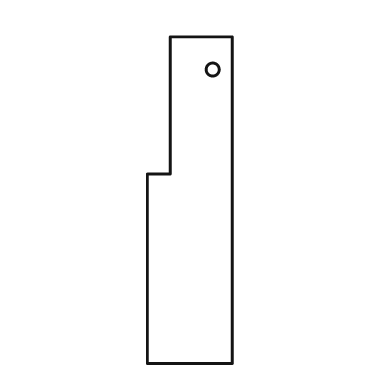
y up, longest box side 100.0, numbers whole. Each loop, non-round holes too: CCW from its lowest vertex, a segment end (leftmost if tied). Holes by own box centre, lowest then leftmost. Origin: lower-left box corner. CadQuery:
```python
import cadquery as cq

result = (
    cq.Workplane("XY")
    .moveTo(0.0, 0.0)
    .lineTo(26.0, 0.0)
    .lineTo(26.0, 100.0)
    .lineTo(7.0, 100.0)
    .lineTo(7.0, 58.0)
    .lineTo(0.0, 58.0)
    .close()
    .moveTo(20.0, 90.0)
    .circle(2.0)
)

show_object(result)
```